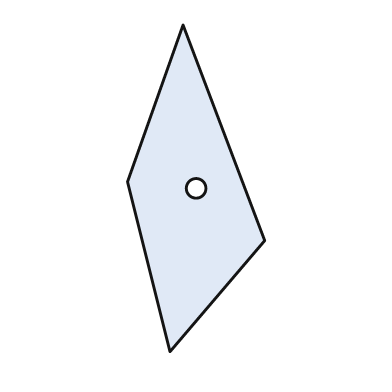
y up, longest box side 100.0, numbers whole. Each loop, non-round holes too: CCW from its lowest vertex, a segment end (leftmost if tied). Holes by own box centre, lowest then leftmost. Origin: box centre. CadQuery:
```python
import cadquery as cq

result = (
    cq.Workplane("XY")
    .moveTo(-8.0, -50.0)
    .lineTo(21.0, -16.0)
    .lineTo(-4.0, 50.0)
    .lineTo(-21.0, 2.0)
    .close()
    .moveTo(0.0, 0.0)
    .circle(3.0)
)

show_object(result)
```